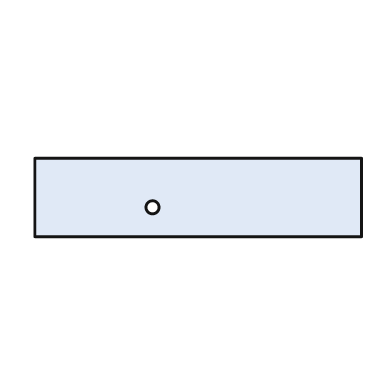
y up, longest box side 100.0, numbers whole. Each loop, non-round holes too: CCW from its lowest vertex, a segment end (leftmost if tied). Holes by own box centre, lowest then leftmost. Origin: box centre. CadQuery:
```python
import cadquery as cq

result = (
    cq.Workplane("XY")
    .moveTo(-50.0, -12.0)
    .lineTo(50.0, -12.0)
    .lineTo(50.0, 12.0)
    .lineTo(-50.0, 12.0)
    .close()
    .moveTo(-14.0, -3.0)
    .circle(2.0)
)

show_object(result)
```